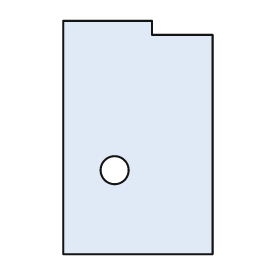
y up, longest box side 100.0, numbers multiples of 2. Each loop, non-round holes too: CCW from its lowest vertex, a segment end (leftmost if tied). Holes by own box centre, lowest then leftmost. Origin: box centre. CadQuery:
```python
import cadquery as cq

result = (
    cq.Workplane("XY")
    .moveTo(-32.0, -50.0)
    .lineTo(32.0, -50.0)
    .lineTo(32.0, 44.0)
    .lineTo(6.0, 44.0)
    .lineTo(6.0, 50.0)
    .lineTo(-32.0, 50.0)
    .close()
    .moveTo(-10.0, -14.0)
    .circle(6.0)
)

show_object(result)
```